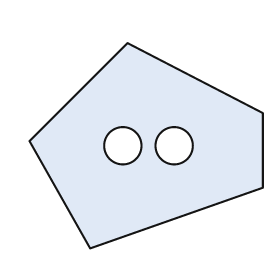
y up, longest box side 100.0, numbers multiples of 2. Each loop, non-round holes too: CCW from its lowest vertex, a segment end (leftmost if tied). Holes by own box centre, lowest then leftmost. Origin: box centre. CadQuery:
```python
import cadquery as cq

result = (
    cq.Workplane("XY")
    .moveTo(-24.0, -44.0)
    .lineTo(50.0, -18.0)
    .lineTo(50.0, 14.0)
    .lineTo(-8.0, 44.0)
    .lineTo(-50.0, 2.0)
    .close()
    .moveTo(-10.0, 0.0)
    .circle(8.0)
    .moveTo(12.0, 0.0)
    .circle(8.0)
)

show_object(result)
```